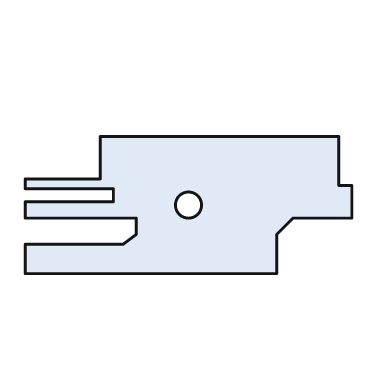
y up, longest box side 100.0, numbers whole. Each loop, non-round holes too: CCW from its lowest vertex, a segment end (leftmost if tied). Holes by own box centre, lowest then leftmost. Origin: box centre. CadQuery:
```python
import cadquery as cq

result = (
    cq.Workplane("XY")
    .moveTo(-50.0, -21.0)
    .lineTo(27.0, -21.0)
    .lineTo(27.0, -9.0)
    .lineTo(32.0, -4.0)
    .lineTo(50.0, -4.0)
    .lineTo(50.0, 6.0)
    .lineTo(46.0, 6.0)
    .lineTo(46.0, 21.0)
    .lineTo(-27.0, 21.0)
    .lineTo(-27.0, 8.0)
    .lineTo(-50.0, 8.0)
    .lineTo(-50.0, 5.0)
    .lineTo(-23.0, 5.0)
    .lineTo(-23.0, 1.0)
    .lineTo(-50.0, 1.0)
    .lineTo(-50.0, -4.0)
    .lineTo(-16.0, -4.0)
    .lineTo(-16.0, -9.0)
    .lineTo(-20.0, -12.0)
    .lineTo(-50.0, -12.0)
    .close()
    .moveTo(0.0, 0.0)
    .circle(4.0)
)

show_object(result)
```